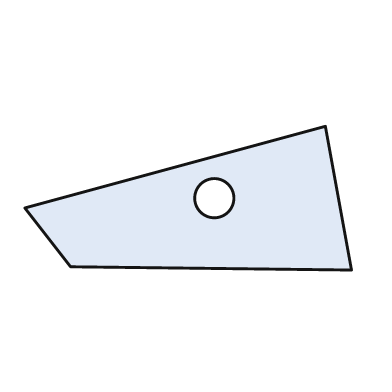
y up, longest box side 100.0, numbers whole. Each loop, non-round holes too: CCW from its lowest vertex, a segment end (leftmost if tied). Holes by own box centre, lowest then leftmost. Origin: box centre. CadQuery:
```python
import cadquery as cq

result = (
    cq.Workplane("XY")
    .moveTo(50.0, -22.0)
    .lineTo(42.0, 22.0)
    .lineTo(-50.0, -3.0)
    .lineTo(-36.0, -21.0)
    .close()
    .moveTo(8.0, 0.0)
    .circle(6.0)
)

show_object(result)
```